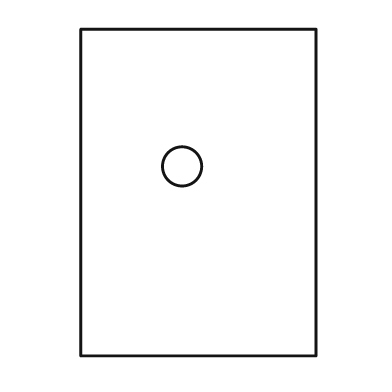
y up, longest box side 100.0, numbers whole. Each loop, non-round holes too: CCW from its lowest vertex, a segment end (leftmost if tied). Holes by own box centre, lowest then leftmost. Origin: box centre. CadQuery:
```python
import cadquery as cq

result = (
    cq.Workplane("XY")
    .moveTo(-36.0, -50.0)
    .lineTo(36.0, -50.0)
    .lineTo(36.0, 50.0)
    .lineTo(-36.0, 50.0)
    .close()
    .moveTo(-5.0, 8.0)
    .circle(6.0)
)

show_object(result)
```